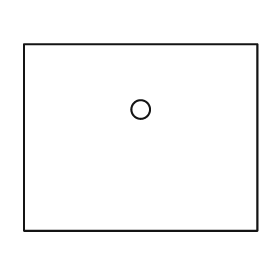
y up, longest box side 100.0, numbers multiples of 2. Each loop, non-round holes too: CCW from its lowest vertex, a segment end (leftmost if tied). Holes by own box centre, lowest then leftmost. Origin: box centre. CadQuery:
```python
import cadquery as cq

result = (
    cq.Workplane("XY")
    .moveTo(-50.0, -40.0)
    .lineTo(50.0, -40.0)
    .lineTo(50.0, 40.0)
    .lineTo(-50.0, 40.0)
    .close()
    .moveTo(0.0, 12.0)
    .circle(4.0)
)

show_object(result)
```